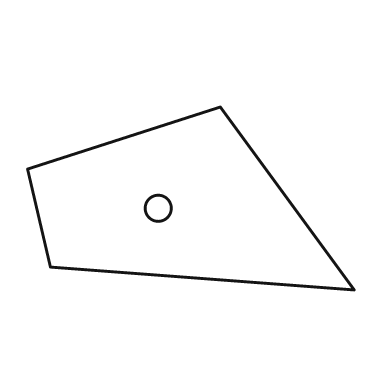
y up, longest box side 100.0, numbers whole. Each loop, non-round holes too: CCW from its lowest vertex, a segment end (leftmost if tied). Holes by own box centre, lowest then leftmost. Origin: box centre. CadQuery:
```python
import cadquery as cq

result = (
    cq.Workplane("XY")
    .moveTo(50.0, -28.0)
    .lineTo(9.0, 28.0)
    .lineTo(-50.0, 9.0)
    .lineTo(-43.0, -21.0)
    .close()
    .moveTo(-10.0, -3.0)
    .circle(4.0)
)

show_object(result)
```